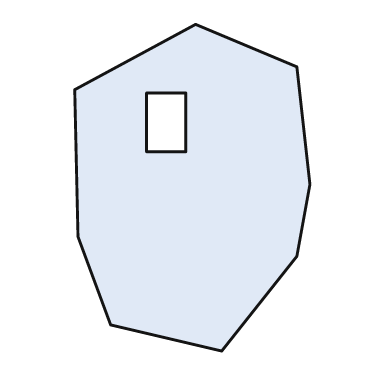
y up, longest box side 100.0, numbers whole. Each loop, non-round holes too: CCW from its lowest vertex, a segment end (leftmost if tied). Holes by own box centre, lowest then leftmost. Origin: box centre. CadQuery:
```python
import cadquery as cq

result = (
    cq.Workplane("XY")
    .moveTo(9.0, -50.0)
    .lineTo(32.0, -21.0)
    .lineTo(36.0, 1.0)
    .lineTo(32.0, 37.0)
    .lineTo(1.0, 50.0)
    .lineTo(-36.0, 30.0)
    .lineTo(-35.0, -15.0)
    .lineTo(-25.0, -42.0)
    .close()
    .moveTo(-14.0, 11.0)
    .lineTo(-2.0, 11.0)
    .lineTo(-2.0, 29.0)
    .lineTo(-14.0, 29.0)
    .close()
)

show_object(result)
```